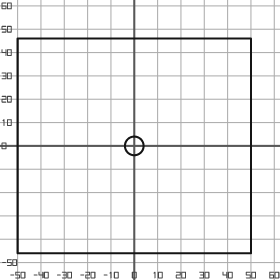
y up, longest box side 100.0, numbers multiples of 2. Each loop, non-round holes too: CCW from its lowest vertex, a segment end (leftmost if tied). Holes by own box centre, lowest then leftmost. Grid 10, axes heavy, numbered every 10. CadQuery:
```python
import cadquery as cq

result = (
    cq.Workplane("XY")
    .moveTo(-50.0, -46.0)
    .lineTo(50.0, -46.0)
    .lineTo(50.0, 46.0)
    .lineTo(-50.0, 46.0)
    .close()
    .moveTo(0.0, 0.0)
    .circle(4.0)
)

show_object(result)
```